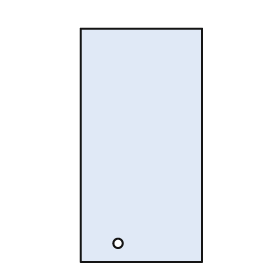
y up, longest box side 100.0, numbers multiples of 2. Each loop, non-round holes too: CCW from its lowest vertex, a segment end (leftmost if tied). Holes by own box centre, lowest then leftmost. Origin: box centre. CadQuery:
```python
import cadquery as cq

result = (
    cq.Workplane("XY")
    .moveTo(-26.0, -50.0)
    .lineTo(26.0, -50.0)
    .lineTo(26.0, 50.0)
    .lineTo(-26.0, 50.0)
    .close()
    .moveTo(-10.0, -42.0)
    .circle(2.0)
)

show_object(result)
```